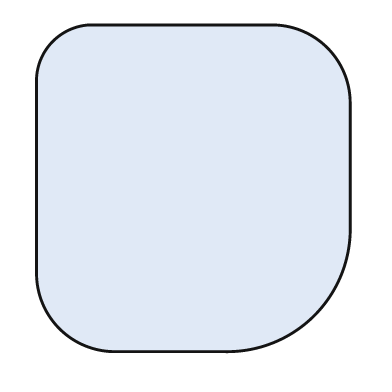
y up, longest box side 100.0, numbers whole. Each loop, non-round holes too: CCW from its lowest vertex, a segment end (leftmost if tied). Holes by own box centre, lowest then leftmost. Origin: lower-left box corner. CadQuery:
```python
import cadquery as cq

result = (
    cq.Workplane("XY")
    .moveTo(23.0, 0.0)
    .lineTo(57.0, 0.0)
    .threePointArc((85.0, 11.0), (96.0, 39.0))
    .lineTo(96.0, 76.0)
    .threePointArc((89.0, 93.0), (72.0, 100.0))
    .lineTo(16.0, 100.0)
    .threePointArc((5.0, 95.0), (0.0, 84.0))
    .lineTo(0.0, 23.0)
    .threePointArc((7.0, 7.0), (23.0, 0.0))
    .close()
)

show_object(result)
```